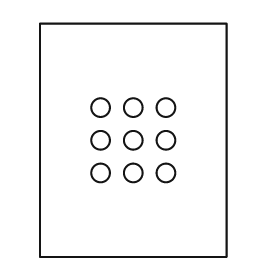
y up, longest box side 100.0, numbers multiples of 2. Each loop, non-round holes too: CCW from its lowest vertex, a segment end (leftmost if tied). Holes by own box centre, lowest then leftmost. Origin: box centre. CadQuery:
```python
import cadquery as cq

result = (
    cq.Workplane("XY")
    .moveTo(-40.0, -50.0)
    .lineTo(40.0, -50.0)
    .lineTo(40.0, 50.0)
    .lineTo(-40.0, 50.0)
    .close()
    .moveTo(-14.0, -14.0)
    .circle(4.0)
    .moveTo(0.0, -14.0)
    .circle(4.0)
    .moveTo(14.0, -14.0)
    .circle(4.0)
    .moveTo(-14.0, 0.0)
    .circle(4.0)
    .moveTo(0.0, 0.0)
    .circle(4.0)
    .moveTo(14.0, 0.0)
    .circle(4.0)
    .moveTo(-14.0, 14.0)
    .circle(4.0)
    .moveTo(0.0, 14.0)
    .circle(4.0)
    .moveTo(14.0, 14.0)
    .circle(4.0)
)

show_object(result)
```